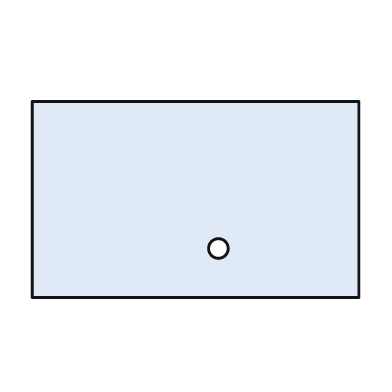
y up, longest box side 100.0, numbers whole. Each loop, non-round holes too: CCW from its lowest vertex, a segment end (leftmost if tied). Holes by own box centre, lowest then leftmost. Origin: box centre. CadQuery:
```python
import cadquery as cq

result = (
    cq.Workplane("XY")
    .moveTo(-50.0, -30.0)
    .lineTo(50.0, -30.0)
    .lineTo(50.0, 30.0)
    .lineTo(-50.0, 30.0)
    .close()
    .moveTo(7.0, -15.0)
    .circle(3.0)
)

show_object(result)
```